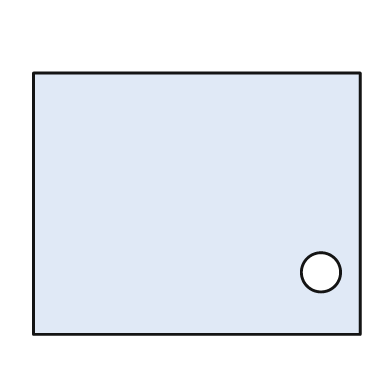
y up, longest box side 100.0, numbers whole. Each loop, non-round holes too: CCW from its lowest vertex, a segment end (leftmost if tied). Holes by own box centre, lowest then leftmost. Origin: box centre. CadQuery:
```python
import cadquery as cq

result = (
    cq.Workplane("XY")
    .moveTo(-50.0, -40.0)
    .lineTo(50.0, -40.0)
    .lineTo(50.0, 40.0)
    .lineTo(-50.0, 40.0)
    .close()
    .moveTo(38.0, -21.0)
    .circle(6.0)
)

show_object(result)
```